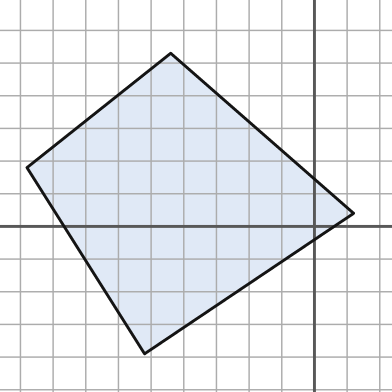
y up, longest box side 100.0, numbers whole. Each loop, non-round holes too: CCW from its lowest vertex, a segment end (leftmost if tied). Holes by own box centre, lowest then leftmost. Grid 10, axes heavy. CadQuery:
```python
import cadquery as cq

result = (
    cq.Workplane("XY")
    .moveTo(-52.0, -39.0)
    .lineTo(12.0, 4.0)
    .lineTo(-44.0, 53.0)
    .lineTo(-88.0, 18.0)
    .close()
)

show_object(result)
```